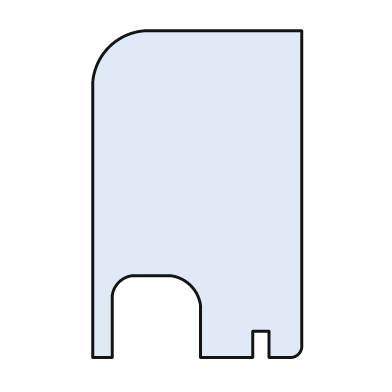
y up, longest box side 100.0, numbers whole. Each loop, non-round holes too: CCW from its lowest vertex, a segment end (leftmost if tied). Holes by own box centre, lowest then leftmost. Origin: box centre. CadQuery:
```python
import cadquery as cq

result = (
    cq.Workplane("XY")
    .moveTo(-32.0, -50.0)
    .lineTo(-26.0, -50.0)
    .lineTo(-26.0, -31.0)
    .threePointArc((-24.0, -27.0), (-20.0, -25.0))
    .lineTo(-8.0, -25.0)
    .threePointArc((-2.0, -28.0), (1.0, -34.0))
    .lineTo(1.0, -50.0)
    .lineTo(17.0, -50.0)
    .lineTo(17.0, -42.0)
    .lineTo(22.0, -42.0)
    .lineTo(22.0, -50.0)
    .lineTo(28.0, -50.0)
    .threePointArc((31.0, -49.0), (32.0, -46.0))
    .lineTo(32.0, 50.0)
    .lineTo(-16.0, 50.0)
    .threePointArc((-27.0, 45.0), (-32.0, 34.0))
    .close()
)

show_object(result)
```